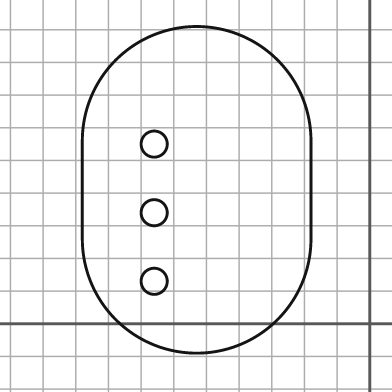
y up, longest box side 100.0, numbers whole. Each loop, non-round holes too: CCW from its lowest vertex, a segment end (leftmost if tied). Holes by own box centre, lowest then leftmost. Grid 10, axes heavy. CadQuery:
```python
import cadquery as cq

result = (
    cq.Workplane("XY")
    .moveTo(-88.0, 26.0)
    .threePointArc((-53.0, -9.0), (-18.0, 26.0))
    .lineTo(-18.0, 56.0)
    .threePointArc((-53.0, 91.0), (-88.0, 56.0))
    .close()
    .moveTo(-66.0, 13.0)
    .circle(4.0)
    .moveTo(-66.0, 34.0)
    .circle(4.0)
    .moveTo(-66.0, 55.0)
    .circle(4.0)
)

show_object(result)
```